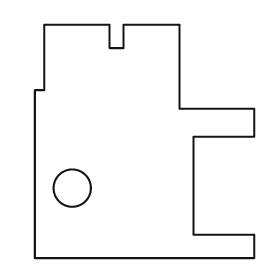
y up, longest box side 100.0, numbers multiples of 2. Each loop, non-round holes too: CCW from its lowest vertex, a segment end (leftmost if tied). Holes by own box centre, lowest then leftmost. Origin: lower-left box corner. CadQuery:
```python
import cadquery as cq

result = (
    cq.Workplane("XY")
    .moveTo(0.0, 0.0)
    .lineTo(94.0, 0.0)
    .lineTo(94.0, 10.0)
    .lineTo(68.0, 10.0)
    .lineTo(68.0, 52.0)
    .lineTo(94.0, 52.0)
    .lineTo(94.0, 64.0)
    .lineTo(62.0, 64.0)
    .lineTo(62.0, 100.0)
    .lineTo(38.0, 100.0)
    .lineTo(38.0, 90.0)
    .lineTo(32.0, 90.0)
    .lineTo(32.0, 100.0)
    .lineTo(4.0, 100.0)
    .lineTo(4.0, 72.0)
    .lineTo(0.0, 72.0)
    .close()
    .moveTo(16.0, 30.0)
    .circle(8.0)
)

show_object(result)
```